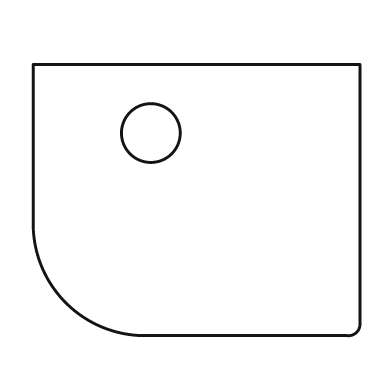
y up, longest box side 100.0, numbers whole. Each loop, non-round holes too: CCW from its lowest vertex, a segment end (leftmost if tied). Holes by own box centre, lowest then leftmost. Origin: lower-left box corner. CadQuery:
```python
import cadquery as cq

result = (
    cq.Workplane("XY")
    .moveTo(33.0, 0.0)
    .lineTo(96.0, 0.0)
    .threePointArc((99.0, 1.0), (100.0, 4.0))
    .lineTo(100.0, 83.0)
    .lineTo(0.0, 83.0)
    .lineTo(0.0, 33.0)
    .threePointArc((10.0, 10.0), (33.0, 0.0))
    .close()
    .moveTo(36.0, 62.0)
    .circle(9.0)
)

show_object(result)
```